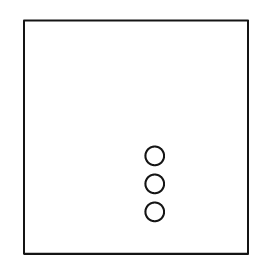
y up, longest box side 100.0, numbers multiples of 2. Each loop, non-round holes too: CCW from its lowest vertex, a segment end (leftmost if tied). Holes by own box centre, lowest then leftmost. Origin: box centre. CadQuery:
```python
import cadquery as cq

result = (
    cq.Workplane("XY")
    .moveTo(-48.0, -50.0)
    .lineTo(48.0, -50.0)
    .lineTo(48.0, 50.0)
    .lineTo(-48.0, 50.0)
    .close()
    .moveTo(8.0, -32.0)
    .circle(4.0)
    .moveTo(8.0, -20.0)
    .circle(4.0)
    .moveTo(8.0, -8.0)
    .circle(4.0)
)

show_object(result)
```